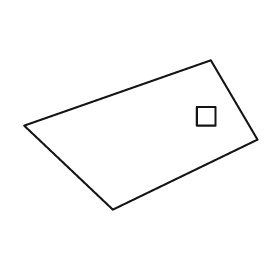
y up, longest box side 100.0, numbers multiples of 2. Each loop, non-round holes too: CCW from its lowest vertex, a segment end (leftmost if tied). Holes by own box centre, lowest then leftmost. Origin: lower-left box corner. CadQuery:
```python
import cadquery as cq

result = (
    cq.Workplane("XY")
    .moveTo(38.0, 0.0)
    .lineTo(100.0, 30.0)
    .lineTo(80.0, 64.0)
    .lineTo(0.0, 36.0)
    .close()
    .moveTo(74.0, 36.0)
    .lineTo(82.0, 36.0)
    .lineTo(82.0, 44.0)
    .lineTo(74.0, 44.0)
    .close()
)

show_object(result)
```